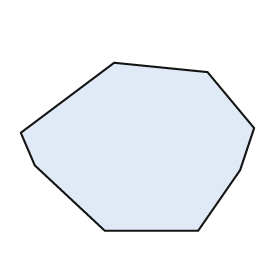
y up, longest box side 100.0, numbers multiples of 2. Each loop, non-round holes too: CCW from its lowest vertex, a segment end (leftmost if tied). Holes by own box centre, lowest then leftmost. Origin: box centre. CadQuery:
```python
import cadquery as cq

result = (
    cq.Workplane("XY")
    .moveTo(-14.0, -36.0)
    .lineTo(26.0, -36.0)
    .lineTo(44.0, -10.0)
    .lineTo(50.0, 8.0)
    .lineTo(30.0, 32.0)
    .lineTo(-10.0, 36.0)
    .lineTo(-50.0, 6.0)
    .lineTo(-44.0, -8.0)
    .close()
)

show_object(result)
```